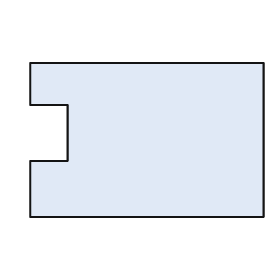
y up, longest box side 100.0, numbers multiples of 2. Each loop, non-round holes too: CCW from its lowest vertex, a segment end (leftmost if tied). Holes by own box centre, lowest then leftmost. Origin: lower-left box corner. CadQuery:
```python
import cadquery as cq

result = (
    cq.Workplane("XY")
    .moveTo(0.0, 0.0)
    .lineTo(100.0, 0.0)
    .lineTo(100.0, 66.0)
    .lineTo(0.0, 66.0)
    .lineTo(0.0, 48.0)
    .lineTo(16.0, 48.0)
    .lineTo(16.0, 24.0)
    .lineTo(0.0, 24.0)
    .close()
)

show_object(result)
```